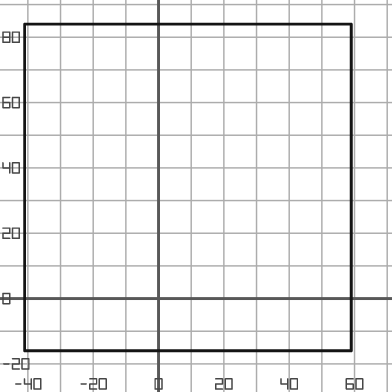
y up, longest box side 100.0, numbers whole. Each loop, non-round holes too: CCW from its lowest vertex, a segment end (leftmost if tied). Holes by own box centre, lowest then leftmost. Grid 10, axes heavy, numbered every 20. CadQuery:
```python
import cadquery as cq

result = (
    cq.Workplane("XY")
    .moveTo(-41.0, -16.0)
    .lineTo(59.0, -16.0)
    .lineTo(59.0, 84.0)
    .lineTo(-41.0, 84.0)
    .close()
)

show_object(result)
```